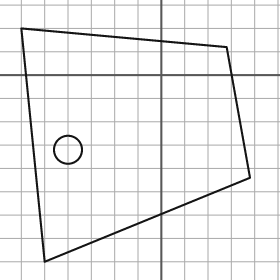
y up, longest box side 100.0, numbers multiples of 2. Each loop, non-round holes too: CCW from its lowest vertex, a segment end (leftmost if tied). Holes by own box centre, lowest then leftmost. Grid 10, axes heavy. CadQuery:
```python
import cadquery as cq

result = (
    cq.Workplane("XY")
    .moveTo(-50.0, -80.0)
    .lineTo(38.0, -44.0)
    .lineTo(28.0, 12.0)
    .lineTo(-60.0, 20.0)
    .close()
    .moveTo(-40.0, -32.0)
    .circle(6.0)
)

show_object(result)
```